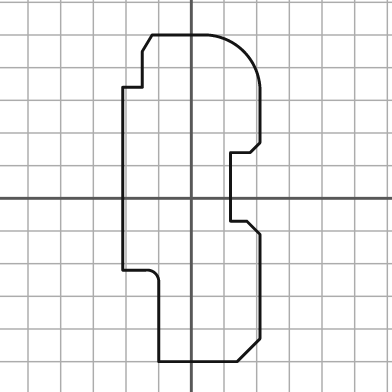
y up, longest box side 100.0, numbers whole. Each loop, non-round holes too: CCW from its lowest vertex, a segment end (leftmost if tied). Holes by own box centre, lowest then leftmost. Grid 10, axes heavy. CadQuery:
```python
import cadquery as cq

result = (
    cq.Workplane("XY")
    .moveTo(-10.0, -50.0)
    .lineTo(14.0, -50.0)
    .lineTo(21.0, -43.0)
    .lineTo(21.0, -11.0)
    .lineTo(17.0, -7.0)
    .lineTo(12.0, -7.0)
    .lineTo(12.0, 14.0)
    .lineTo(18.0, 14.0)
    .lineTo(21.0, 17.0)
    .lineTo(21.0, 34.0)
    .threePointArc((16.0, 45.0), (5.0, 50.0))
    .lineTo(-12.0, 50.0)
    .lineTo(-15.0, 45.0)
    .lineTo(-15.0, 34.0)
    .lineTo(-21.0, 34.0)
    .lineTo(-21.0, -22.0)
    .lineTo(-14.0, -22.0)
    .threePointArc((-11.0, -23.0), (-10.0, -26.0))
    .close()
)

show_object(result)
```